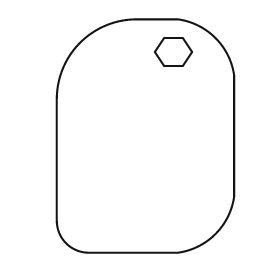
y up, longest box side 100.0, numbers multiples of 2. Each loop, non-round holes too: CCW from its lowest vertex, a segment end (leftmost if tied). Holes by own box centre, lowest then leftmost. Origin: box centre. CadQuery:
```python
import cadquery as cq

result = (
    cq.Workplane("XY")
    .moveTo(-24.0, -50.0)
    .lineTo(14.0, -50.0)
    .threePointArc((30.0, -42.0), (38.0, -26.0))
    .lineTo(38.0, 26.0)
    .threePointArc((30.0, 42.0), (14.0, 50.0))
    .lineTo(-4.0, 50.0)
    .threePointArc((-28.0, 40.0), (-38.0, 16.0))
    .lineTo(-38.0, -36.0)
    .threePointArc((-34.0, -46.0), (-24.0, -50.0))
    .close()
    .moveTo(8.0, 30.0)
    .lineTo(16.0, 30.0)
    .lineTo(20.0, 36.0)
    .lineTo(16.0, 42.0)
    .lineTo(8.0, 42.0)
    .lineTo(4.0, 36.0)
    .close()
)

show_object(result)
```